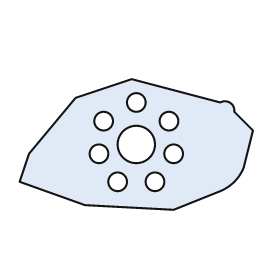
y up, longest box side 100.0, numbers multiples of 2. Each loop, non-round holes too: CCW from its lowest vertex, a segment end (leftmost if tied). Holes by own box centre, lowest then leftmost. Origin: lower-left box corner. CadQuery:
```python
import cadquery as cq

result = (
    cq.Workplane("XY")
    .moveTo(66.0, 0.0)
    .lineTo(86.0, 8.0)
    .threePointArc((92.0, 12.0), (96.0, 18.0))
    .lineTo(100.0, 34.0)
    .lineTo(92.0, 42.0)
    .threePointArc((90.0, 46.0), (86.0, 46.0))
    .lineTo(48.0, 56.0)
    .lineTo(24.0, 48.0)
    .lineTo(4.0, 24.0)
    .lineTo(0.0, 12.0)
    .lineTo(28.0, 2.0)
    .close()
    .moveTo(42.0, 12.0)
    .circle(4.0)
    .moveTo(58.0, 12.0)
    .circle(4.0)
    .moveTo(34.0, 24.0)
    .circle(4.0)
    .moveTo(66.0, 24.0)
    .circle(4.0)
    .moveTo(50.0, 28.0)
    .circle(8.0)
    .moveTo(36.0, 38.0)
    .circle(4.0)
    .moveTo(64.0, 38.0)
    .circle(4.0)
    .moveTo(50.0, 46.0)
    .circle(4.0)
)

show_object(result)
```